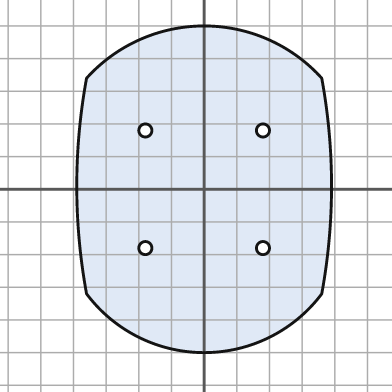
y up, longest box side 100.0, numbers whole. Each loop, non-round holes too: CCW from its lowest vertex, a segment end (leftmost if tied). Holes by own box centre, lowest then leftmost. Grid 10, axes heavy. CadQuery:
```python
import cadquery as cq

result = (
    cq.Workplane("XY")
    .moveTo(-36.0, -32.0)
    .threePointArc((0.0, -50.0), (36.0, -32.0))
    .threePointArc((39.0, 1.0), (36.0, 34.0))
    .threePointArc((0.0, 50.0), (-36.0, 34.0))
    .threePointArc((-39.0, 1.0), (-36.0, -32.0))
    .close()
    .moveTo(-18.0, -18.0)
    .circle(2.0)
    .moveTo(18.0, -18.0)
    .circle(2.0)
    .moveTo(-18.0, 18.0)
    .circle(2.0)
    .moveTo(18.0, 18.0)
    .circle(2.0)
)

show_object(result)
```